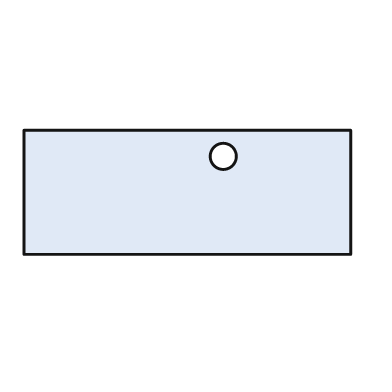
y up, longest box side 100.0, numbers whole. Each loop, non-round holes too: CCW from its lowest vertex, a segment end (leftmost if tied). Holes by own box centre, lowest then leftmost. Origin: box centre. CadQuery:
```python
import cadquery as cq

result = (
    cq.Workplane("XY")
    .moveTo(-50.0, -19.0)
    .lineTo(50.0, -19.0)
    .lineTo(50.0, 19.0)
    .lineTo(-50.0, 19.0)
    .close()
    .moveTo(11.0, 11.0)
    .circle(4.0)
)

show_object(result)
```